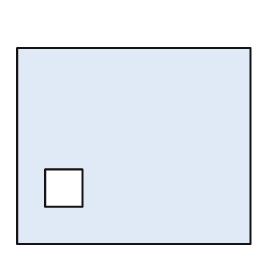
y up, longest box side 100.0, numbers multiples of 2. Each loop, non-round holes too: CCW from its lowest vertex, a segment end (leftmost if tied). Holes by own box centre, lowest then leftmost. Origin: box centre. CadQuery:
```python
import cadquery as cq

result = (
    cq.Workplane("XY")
    .moveTo(-50.0, -42.0)
    .lineTo(50.0, -42.0)
    .lineTo(50.0, 42.0)
    .lineTo(-50.0, 42.0)
    .close()
    .moveTo(-38.0, -26.0)
    .lineTo(-22.0, -26.0)
    .lineTo(-22.0, -10.0)
    .lineTo(-38.0, -10.0)
    .close()
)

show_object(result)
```